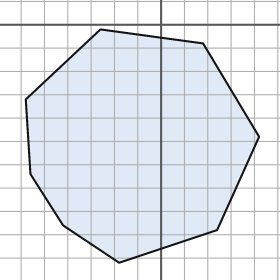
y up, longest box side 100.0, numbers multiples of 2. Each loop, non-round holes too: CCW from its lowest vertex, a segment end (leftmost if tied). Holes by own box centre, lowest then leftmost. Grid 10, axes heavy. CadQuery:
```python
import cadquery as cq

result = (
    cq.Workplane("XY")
    .moveTo(-18.0, -102.0)
    .lineTo(24.0, -88.0)
    .lineTo(42.0, -48.0)
    .lineTo(18.0, -8.0)
    .lineTo(-26.0, -2.0)
    .lineTo(-58.0, -32.0)
    .lineTo(-56.0, -64.0)
    .lineTo(-42.0, -86.0)
    .close()
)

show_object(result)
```